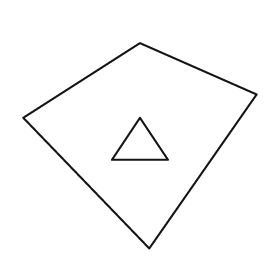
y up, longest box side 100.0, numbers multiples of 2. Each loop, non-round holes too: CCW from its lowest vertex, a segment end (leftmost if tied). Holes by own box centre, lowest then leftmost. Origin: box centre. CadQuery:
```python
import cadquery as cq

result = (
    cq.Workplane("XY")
    .moveTo(4.0, -44.0)
    .lineTo(50.0, 22.0)
    .lineTo(0.0, 44.0)
    .lineTo(-50.0, 12.0)
    .close()
    .moveTo(-12.0, -6.0)
    .lineTo(12.0, -6.0)
    .lineTo(0.0, 12.0)
    .close()
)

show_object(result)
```